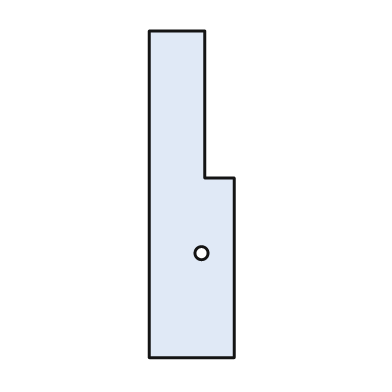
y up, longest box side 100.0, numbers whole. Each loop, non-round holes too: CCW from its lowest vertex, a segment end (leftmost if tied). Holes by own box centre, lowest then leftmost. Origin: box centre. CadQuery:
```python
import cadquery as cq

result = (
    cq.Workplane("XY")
    .moveTo(-13.0, -50.0)
    .lineTo(13.0, -50.0)
    .lineTo(13.0, 5.0)
    .lineTo(4.0, 5.0)
    .lineTo(4.0, 50.0)
    .lineTo(-13.0, 50.0)
    .close()
    .moveTo(3.0, -18.0)
    .circle(2.0)
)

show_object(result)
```